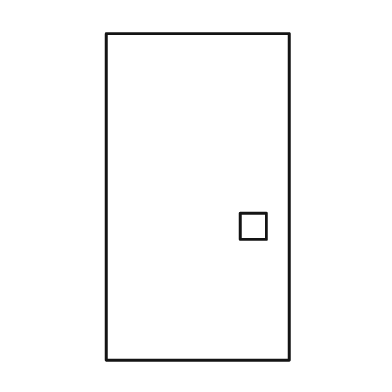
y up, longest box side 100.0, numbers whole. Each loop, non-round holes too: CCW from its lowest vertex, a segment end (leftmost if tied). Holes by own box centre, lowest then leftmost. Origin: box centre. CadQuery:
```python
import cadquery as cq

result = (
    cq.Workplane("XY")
    .moveTo(-28.0, -50.0)
    .lineTo(28.0, -50.0)
    .lineTo(28.0, 50.0)
    .lineTo(-28.0, 50.0)
    .close()
    .moveTo(13.0, -13.0)
    .lineTo(21.0, -13.0)
    .lineTo(21.0, -5.0)
    .lineTo(13.0, -5.0)
    .close()
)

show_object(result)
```